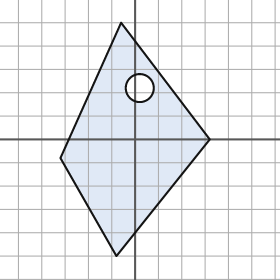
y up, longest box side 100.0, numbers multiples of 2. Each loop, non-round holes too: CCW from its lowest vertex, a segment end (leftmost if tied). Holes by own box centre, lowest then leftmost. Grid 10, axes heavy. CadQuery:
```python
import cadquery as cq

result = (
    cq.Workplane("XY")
    .moveTo(-8.0, -50.0)
    .lineTo(32.0, 0.0)
    .lineTo(-6.0, 50.0)
    .lineTo(-32.0, -8.0)
    .close()
    .moveTo(2.0, 22.0)
    .circle(6.0)
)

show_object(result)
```